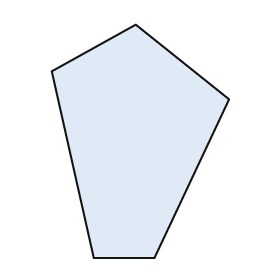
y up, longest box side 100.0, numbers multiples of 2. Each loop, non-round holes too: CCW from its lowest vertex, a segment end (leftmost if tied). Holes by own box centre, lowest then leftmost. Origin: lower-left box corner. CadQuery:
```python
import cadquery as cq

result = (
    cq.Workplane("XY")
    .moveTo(18.0, 0.0)
    .lineTo(44.0, 0.0)
    .lineTo(76.0, 68.0)
    .lineTo(36.0, 100.0)
    .lineTo(0.0, 80.0)
    .close()
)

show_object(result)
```